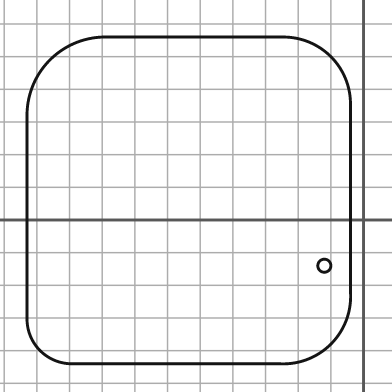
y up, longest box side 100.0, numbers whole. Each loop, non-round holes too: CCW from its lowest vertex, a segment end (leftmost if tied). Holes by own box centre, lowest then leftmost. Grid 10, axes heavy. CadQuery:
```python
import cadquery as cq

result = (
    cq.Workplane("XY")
    .moveTo(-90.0, -44.0)
    .lineTo(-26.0, -44.0)
    .threePointArc((-10.0, -38.0), (-4.0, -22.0))
    .lineTo(-4.0, 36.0)
    .threePointArc((-10.0, 50.0), (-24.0, 56.0))
    .lineTo(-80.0, 56.0)
    .threePointArc((-96.0, 49.0), (-103.0, 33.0))
    .lineTo(-103.0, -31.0)
    .threePointArc((-99.0, -40.0), (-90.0, -44.0))
    .close()
    .moveTo(-12.0, -14.0)
    .circle(2.0)
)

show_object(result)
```